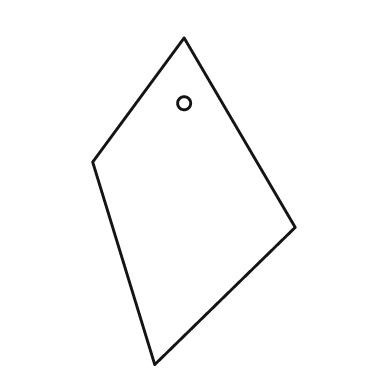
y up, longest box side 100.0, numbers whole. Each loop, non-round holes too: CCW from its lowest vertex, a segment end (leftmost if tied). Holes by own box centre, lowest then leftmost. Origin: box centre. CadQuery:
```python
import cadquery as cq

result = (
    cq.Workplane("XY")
    .moveTo(-12.0, -50.0)
    .lineTo(31.0, -8.0)
    .lineTo(-3.0, 50.0)
    .lineTo(-31.0, 12.0)
    .close()
    .moveTo(-3.0, 30.0)
    .circle(2.0)
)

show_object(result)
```